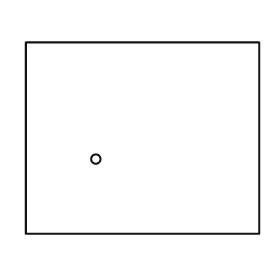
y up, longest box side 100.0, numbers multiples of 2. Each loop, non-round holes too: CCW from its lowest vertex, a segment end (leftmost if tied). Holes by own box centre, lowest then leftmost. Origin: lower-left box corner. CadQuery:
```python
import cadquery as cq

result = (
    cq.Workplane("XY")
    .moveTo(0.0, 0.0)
    .lineTo(100.0, 0.0)
    .lineTo(100.0, 82.0)
    .lineTo(0.0, 82.0)
    .close()
    .moveTo(30.0, 32.0)
    .circle(2.0)
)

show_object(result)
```